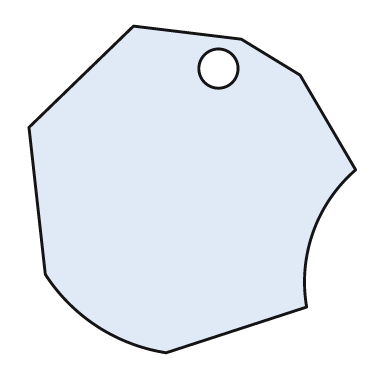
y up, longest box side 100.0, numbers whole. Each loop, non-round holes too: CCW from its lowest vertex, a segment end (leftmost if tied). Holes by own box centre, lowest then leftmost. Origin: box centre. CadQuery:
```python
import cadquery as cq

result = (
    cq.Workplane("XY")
    .moveTo(-8.0, -50.0)
    .lineTo(35.0, -36.0)
    .threePointArc((37.0, -13.0), (50.0, 6.0))
    .lineTo(33.0, 35.0)
    .lineTo(15.0, 46.0)
    .lineTo(-18.0, 50.0)
    .lineTo(-50.0, 19.0)
    .lineTo(-45.0, -26.0)
    .threePointArc((-29.0, -42.0), (-8.0, -50.0))
    .close()
    .moveTo(8.0, 37.0)
    .circle(6.0)
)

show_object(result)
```